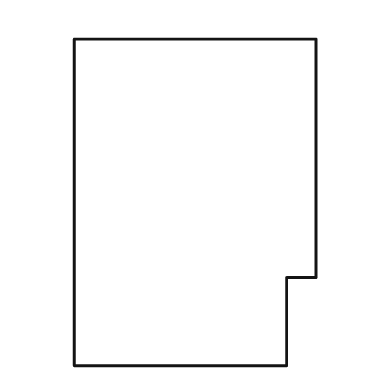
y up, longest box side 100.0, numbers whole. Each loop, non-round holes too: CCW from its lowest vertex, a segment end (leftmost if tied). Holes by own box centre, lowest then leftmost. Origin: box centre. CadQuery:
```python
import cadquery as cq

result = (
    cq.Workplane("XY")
    .moveTo(-37.0, -50.0)
    .lineTo(28.0, -50.0)
    .lineTo(28.0, -23.0)
    .lineTo(37.0, -23.0)
    .lineTo(37.0, 50.0)
    .lineTo(-37.0, 50.0)
    .close()
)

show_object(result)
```